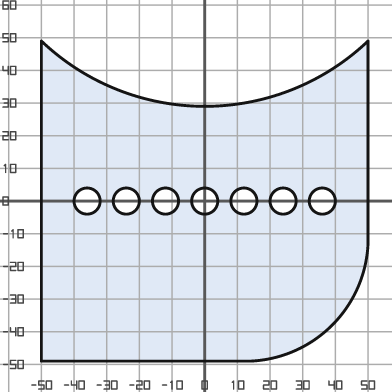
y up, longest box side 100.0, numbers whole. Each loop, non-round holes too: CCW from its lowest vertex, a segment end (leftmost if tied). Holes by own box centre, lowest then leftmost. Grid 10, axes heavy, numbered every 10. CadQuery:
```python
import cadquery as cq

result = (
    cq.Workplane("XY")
    .moveTo(-50.0, -49.0)
    .lineTo(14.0, -49.0)
    .threePointArc((39.0, -38.0), (50.0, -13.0))
    .lineTo(50.0, 49.0)
    .threePointArc((0.0, 29.0), (-50.0, 49.0))
    .close()
    .moveTo(-36.0, 0.0)
    .circle(4.0)
    .moveTo(-24.0, 0.0)
    .circle(4.0)
    .moveTo(-12.0, 0.0)
    .circle(4.0)
    .moveTo(0.0, 0.0)
    .circle(4.0)
    .moveTo(12.0, 0.0)
    .circle(4.0)
    .moveTo(24.0, 0.0)
    .circle(4.0)
    .moveTo(36.0, 0.0)
    .circle(4.0)
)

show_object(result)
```